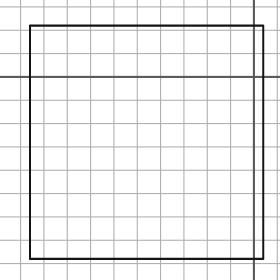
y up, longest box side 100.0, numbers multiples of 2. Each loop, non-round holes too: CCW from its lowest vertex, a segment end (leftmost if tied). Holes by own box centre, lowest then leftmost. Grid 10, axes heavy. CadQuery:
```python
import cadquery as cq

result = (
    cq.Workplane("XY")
    .moveTo(-96.0, -78.0)
    .lineTo(4.0, -78.0)
    .lineTo(4.0, 22.0)
    .lineTo(-96.0, 22.0)
    .close()
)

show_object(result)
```